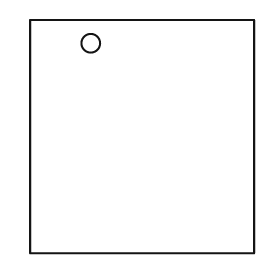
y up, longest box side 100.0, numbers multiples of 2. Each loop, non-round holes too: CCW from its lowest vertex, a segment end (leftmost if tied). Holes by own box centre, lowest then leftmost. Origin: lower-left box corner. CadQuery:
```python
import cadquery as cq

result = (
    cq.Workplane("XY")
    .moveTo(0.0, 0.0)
    .lineTo(96.0, 0.0)
    .lineTo(96.0, 100.0)
    .lineTo(0.0, 100.0)
    .close()
    .moveTo(26.0, 90.0)
    .circle(4.0)
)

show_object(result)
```